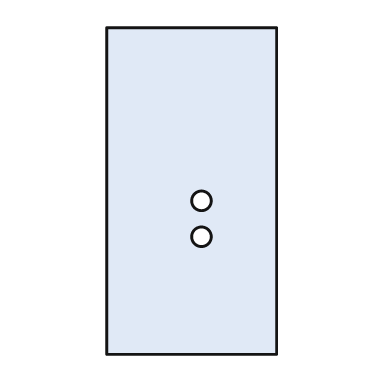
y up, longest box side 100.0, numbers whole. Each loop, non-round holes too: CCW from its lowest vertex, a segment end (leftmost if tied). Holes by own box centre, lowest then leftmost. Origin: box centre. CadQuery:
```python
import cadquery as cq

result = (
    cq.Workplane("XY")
    .moveTo(-26.0, -50.0)
    .lineTo(26.0, -50.0)
    .lineTo(26.0, 50.0)
    .lineTo(-26.0, 50.0)
    .close()
    .moveTo(3.0, -14.0)
    .circle(3.0)
    .moveTo(3.0, -3.0)
    .circle(3.0)
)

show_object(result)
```